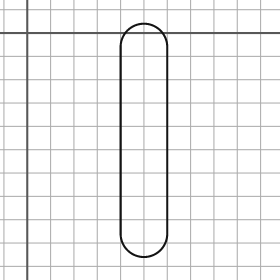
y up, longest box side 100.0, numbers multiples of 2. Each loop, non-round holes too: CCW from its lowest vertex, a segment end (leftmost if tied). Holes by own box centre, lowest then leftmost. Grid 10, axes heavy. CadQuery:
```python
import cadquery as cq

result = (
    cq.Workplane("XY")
    .moveTo(40.0, -86.0)
    .threePointArc((50.0, -96.0), (60.0, -86.0))
    .lineTo(60.0, -6.0)
    .threePointArc((50.0, 4.0), (40.0, -6.0))
    .close()
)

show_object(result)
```